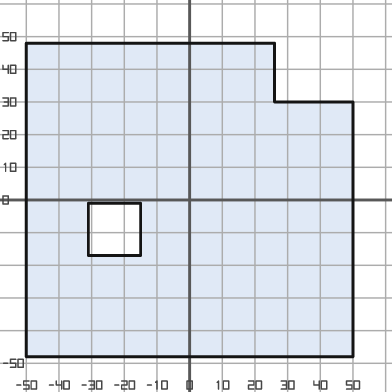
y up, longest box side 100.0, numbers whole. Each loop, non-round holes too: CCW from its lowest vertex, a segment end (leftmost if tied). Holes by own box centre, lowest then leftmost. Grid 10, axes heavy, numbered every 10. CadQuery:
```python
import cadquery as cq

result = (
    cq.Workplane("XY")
    .moveTo(-50.0, -48.0)
    .lineTo(50.0, -48.0)
    .lineTo(50.0, 30.0)
    .lineTo(26.0, 30.0)
    .lineTo(26.0, 48.0)
    .lineTo(-50.0, 48.0)
    .close()
    .moveTo(-31.0, -17.0)
    .lineTo(-15.0, -17.0)
    .lineTo(-15.0, -1.0)
    .lineTo(-31.0, -1.0)
    .close()
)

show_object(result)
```